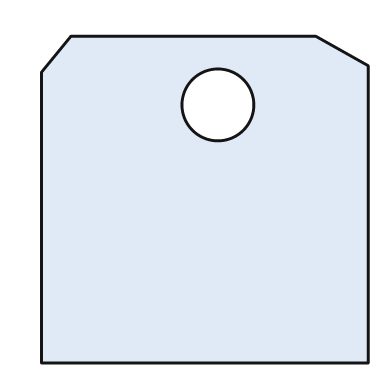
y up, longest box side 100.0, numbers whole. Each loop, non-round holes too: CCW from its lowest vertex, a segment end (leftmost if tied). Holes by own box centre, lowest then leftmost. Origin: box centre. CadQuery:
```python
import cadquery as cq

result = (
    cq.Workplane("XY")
    .moveTo(-50.0, -50.0)
    .lineTo(50.0, -50.0)
    .lineTo(50.0, 41.0)
    .lineTo(34.0, 50.0)
    .lineTo(-41.0, 50.0)
    .lineTo(-50.0, 39.0)
    .close()
    .moveTo(4.0, 29.0)
    .circle(11.0)
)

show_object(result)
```